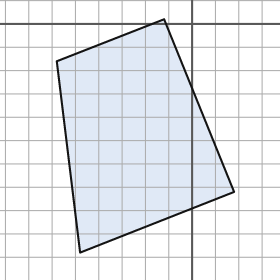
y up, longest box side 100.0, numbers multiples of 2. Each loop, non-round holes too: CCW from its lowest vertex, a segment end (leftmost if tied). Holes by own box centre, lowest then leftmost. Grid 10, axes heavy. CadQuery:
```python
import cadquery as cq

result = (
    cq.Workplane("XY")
    .moveTo(-48.0, -98.0)
    .lineTo(18.0, -72.0)
    .lineTo(-12.0, 2.0)
    .lineTo(-58.0, -16.0)
    .close()
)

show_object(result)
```